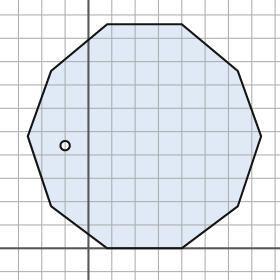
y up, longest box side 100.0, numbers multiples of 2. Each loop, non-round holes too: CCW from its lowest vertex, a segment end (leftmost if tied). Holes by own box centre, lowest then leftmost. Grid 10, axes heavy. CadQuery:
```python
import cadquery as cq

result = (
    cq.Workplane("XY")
    .moveTo(8.0, 0.0)
    .lineTo(40.0, 0.0)
    .lineTo(64.0, 18.0)
    .lineTo(74.0, 48.0)
    .lineTo(64.0, 76.0)
    .lineTo(40.0, 96.0)
    .lineTo(8.0, 96.0)
    .lineTo(-16.0, 76.0)
    .lineTo(-26.0, 48.0)
    .lineTo(-16.0, 18.0)
    .close()
    .moveTo(-10.0, 44.0)
    .circle(2.0)
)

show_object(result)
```